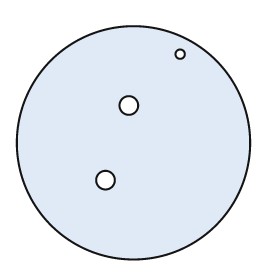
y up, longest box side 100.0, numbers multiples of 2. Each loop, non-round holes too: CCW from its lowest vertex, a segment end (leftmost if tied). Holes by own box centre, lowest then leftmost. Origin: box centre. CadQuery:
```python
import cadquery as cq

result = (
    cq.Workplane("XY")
    .moveTo(0.0, 0.0)
    .circle(50.0)
    .moveTo(-12.0, -16.0)
    .circle(4.0)
    .moveTo(-2.0, 16.0)
    .circle(4.0)
    .moveTo(20.0, 38.0)
    .circle(2.0)
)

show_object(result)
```